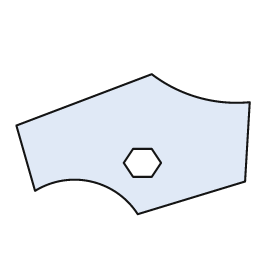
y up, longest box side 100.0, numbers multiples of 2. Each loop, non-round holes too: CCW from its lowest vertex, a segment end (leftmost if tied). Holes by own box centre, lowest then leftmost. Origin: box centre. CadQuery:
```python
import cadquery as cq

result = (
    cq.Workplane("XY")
    .moveTo(2.0, -30.0)
    .lineTo(48.0, -16.0)
    .lineTo(50.0, 18.0)
    .threePointArc((28.0, 20.0), (8.0, 30.0))
    .lineTo(-50.0, 8.0)
    .lineTo(-42.0, -20.0)
    .threePointArc((-18.0, -16.0), (2.0, -30.0))
    .close()
    .moveTo(0.0, -14.0)
    .lineTo(8.0, -14.0)
    .lineTo(12.0, -8.0)
    .lineTo(8.0, -2.0)
    .lineTo(0.0, -2.0)
    .lineTo(-4.0, -8.0)
    .close()
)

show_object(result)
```